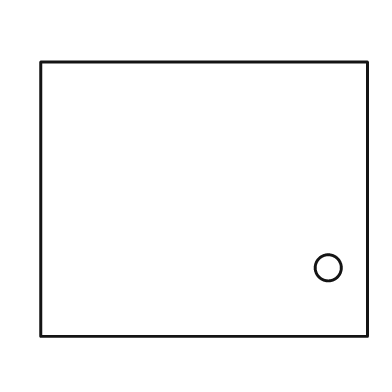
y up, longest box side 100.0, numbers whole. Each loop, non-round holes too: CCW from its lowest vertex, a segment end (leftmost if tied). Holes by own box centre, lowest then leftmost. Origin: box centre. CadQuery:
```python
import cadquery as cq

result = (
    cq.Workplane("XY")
    .moveTo(-50.0, -42.0)
    .lineTo(50.0, -42.0)
    .lineTo(50.0, 42.0)
    .lineTo(-50.0, 42.0)
    .close()
    .moveTo(38.0, -21.0)
    .circle(4.0)
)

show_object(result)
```